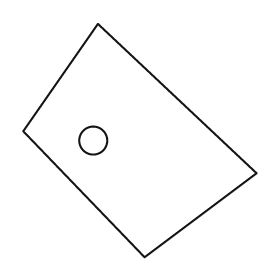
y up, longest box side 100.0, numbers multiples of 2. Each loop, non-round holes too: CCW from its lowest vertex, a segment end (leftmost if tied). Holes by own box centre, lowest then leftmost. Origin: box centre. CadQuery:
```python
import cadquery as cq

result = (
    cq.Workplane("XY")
    .moveTo(2.0, -50.0)
    .lineTo(50.0, -14.0)
    .lineTo(-18.0, 50.0)
    .lineTo(-50.0, 4.0)
    .close()
    .moveTo(-20.0, 0.0)
    .circle(6.0)
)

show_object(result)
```